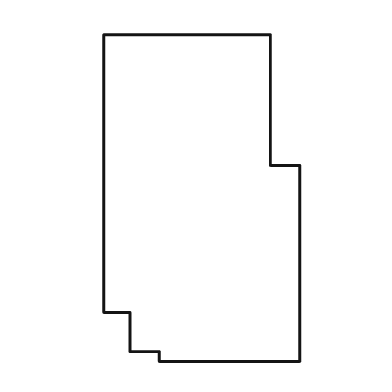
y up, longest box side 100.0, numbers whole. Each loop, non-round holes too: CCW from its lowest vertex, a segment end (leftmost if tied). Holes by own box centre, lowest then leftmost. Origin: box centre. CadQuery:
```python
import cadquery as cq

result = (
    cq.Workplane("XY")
    .moveTo(-13.0, -50.0)
    .lineTo(30.0, -50.0)
    .lineTo(30.0, 10.0)
    .lineTo(21.0, 10.0)
    .lineTo(21.0, 50.0)
    .lineTo(-30.0, 50.0)
    .lineTo(-30.0, -35.0)
    .lineTo(-22.0, -35.0)
    .lineTo(-22.0, -47.0)
    .lineTo(-13.0, -47.0)
    .close()
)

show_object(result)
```